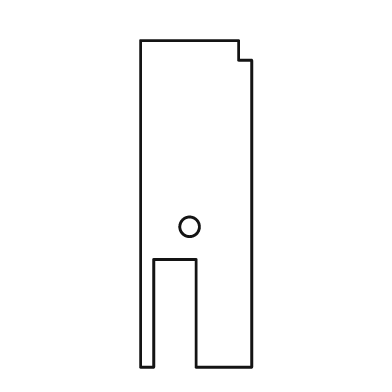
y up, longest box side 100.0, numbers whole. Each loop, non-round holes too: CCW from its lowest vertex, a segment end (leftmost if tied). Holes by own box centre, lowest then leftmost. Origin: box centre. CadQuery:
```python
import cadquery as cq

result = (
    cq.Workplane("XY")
    .moveTo(-17.0, -50.0)
    .lineTo(-13.0, -50.0)
    .lineTo(-13.0, -17.0)
    .lineTo(0.0, -17.0)
    .lineTo(0.0, -50.0)
    .lineTo(17.0, -50.0)
    .lineTo(17.0, 44.0)
    .lineTo(13.0, 44.0)
    .lineTo(13.0, 50.0)
    .lineTo(-17.0, 50.0)
    .close()
    .moveTo(-2.0, -7.0)
    .circle(3.0)
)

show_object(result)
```